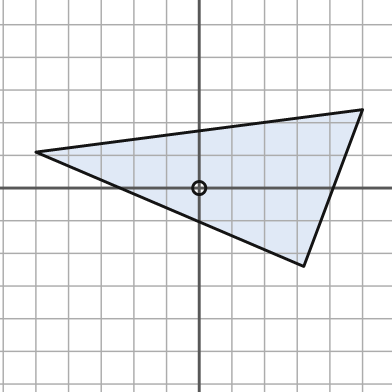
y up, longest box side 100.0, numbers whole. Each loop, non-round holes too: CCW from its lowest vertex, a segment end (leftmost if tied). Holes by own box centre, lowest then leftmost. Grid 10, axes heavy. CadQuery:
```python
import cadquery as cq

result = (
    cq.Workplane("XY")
    .moveTo(32.0, -24.0)
    .lineTo(50.0, 24.0)
    .lineTo(-50.0, 11.0)
    .close()
    .moveTo(0.0, 0.0)
    .circle(2.0)
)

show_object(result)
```